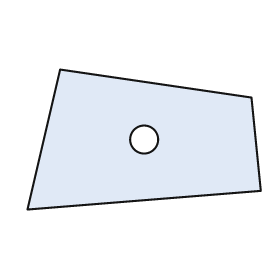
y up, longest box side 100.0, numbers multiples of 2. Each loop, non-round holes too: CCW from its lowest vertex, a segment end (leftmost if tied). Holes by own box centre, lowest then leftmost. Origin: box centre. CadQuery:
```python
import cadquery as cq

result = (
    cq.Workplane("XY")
    .moveTo(-50.0, -30.0)
    .lineTo(50.0, -22.0)
    .lineTo(46.0, 18.0)
    .lineTo(-36.0, 30.0)
    .close()
    .moveTo(0.0, 0.0)
    .circle(6.0)
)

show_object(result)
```